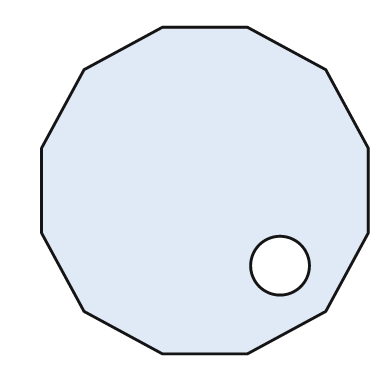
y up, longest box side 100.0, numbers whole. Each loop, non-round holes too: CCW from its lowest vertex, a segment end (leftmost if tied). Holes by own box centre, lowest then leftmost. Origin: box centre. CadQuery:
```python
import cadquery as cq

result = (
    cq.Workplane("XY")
    .moveTo(-13.0, -50.0)
    .lineTo(13.0, -50.0)
    .lineTo(37.0, -37.0)
    .lineTo(50.0, -13.0)
    .lineTo(50.0, 13.0)
    .lineTo(37.0, 37.0)
    .lineTo(13.0, 50.0)
    .lineTo(-13.0, 50.0)
    .lineTo(-37.0, 37.0)
    .lineTo(-50.0, 13.0)
    .lineTo(-50.0, -13.0)
    .lineTo(-37.0, -37.0)
    .close()
    .moveTo(23.0, -23.0)
    .circle(9.0)
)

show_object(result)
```